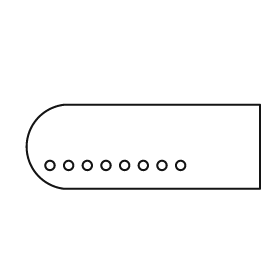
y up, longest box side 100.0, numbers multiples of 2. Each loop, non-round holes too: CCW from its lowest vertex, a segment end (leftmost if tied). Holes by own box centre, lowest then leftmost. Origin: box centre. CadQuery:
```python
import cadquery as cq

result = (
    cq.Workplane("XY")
    .moveTo(-34.0, -18.0)
    .lineTo(50.0, -18.0)
    .lineTo(50.0, 18.0)
    .lineTo(-34.0, 18.0)
    .threePointArc((-50.0, 0.0), (-34.0, -18.0))
    .close()
    .moveTo(-40.0, -8.0)
    .circle(2.0)
    .moveTo(-32.0, -8.0)
    .circle(2.0)
    .moveTo(-24.0, -8.0)
    .circle(2.0)
    .moveTo(-16.0, -8.0)
    .circle(2.0)
    .moveTo(-8.0, -8.0)
    .circle(2.0)
    .moveTo(0.0, -8.0)
    .circle(2.0)
    .moveTo(8.0, -8.0)
    .circle(2.0)
    .moveTo(16.0, -8.0)
    .circle(2.0)
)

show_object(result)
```